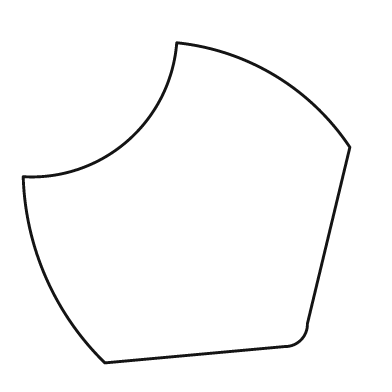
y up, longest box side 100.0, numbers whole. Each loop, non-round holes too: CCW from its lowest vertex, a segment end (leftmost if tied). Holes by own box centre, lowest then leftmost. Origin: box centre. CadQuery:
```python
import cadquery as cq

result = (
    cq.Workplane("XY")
    .moveTo(-25.0, -49.0)
    .lineTo(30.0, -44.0)
    .threePointArc((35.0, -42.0), (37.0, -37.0))
    .lineTo(50.0, 17.0)
    .threePointArc((27.0, 39.0), (-3.0, 49.0))
    .threePointArc((-18.0, 19.0), (-50.0, 8.0))
    .threePointArc((-43.0, -23.0), (-25.0, -49.0))
    .close()
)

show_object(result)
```